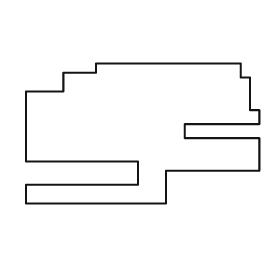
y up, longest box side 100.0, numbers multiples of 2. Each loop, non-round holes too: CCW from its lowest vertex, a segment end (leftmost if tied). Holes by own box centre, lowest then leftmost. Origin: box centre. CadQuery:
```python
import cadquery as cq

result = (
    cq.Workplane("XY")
    .moveTo(-50.0, -30.0)
    .lineTo(10.0, -30.0)
    .lineTo(10.0, -16.0)
    .lineTo(50.0, -16.0)
    .lineTo(50.0, -2.0)
    .lineTo(18.0, -2.0)
    .lineTo(18.0, 4.0)
    .lineTo(50.0, 4.0)
    .lineTo(50.0, 10.0)
    .lineTo(46.0, 10.0)
    .lineTo(46.0, 24.0)
    .lineTo(42.0, 24.0)
    .lineTo(42.0, 30.0)
    .lineTo(-20.0, 30.0)
    .lineTo(-20.0, 26.0)
    .lineTo(-34.0, 26.0)
    .lineTo(-34.0, 18.0)
    .lineTo(-50.0, 18.0)
    .lineTo(-50.0, -12.0)
    .lineTo(-2.0, -12.0)
    .lineTo(-2.0, -22.0)
    .lineTo(-50.0, -22.0)
    .close()
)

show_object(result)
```